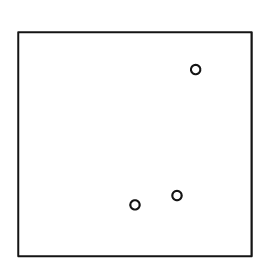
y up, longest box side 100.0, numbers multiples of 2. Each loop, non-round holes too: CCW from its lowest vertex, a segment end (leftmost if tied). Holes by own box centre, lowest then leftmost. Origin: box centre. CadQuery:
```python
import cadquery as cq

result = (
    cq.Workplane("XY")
    .moveTo(-50.0, -48.0)
    .lineTo(50.0, -48.0)
    .lineTo(50.0, 48.0)
    .lineTo(-50.0, 48.0)
    .close()
    .moveTo(0.0, -26.0)
    .circle(2.0)
    .moveTo(18.0, -22.0)
    .circle(2.0)
    .moveTo(26.0, 32.0)
    .circle(2.0)
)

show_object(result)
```